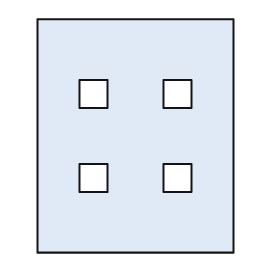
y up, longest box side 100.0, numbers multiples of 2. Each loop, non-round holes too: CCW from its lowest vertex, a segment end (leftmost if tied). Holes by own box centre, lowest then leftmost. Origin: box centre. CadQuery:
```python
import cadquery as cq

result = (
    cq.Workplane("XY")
    .moveTo(-42.0, -50.0)
    .lineTo(42.0, -50.0)
    .lineTo(42.0, 50.0)
    .lineTo(-42.0, 50.0)
    .close()
    .moveTo(-24.0, -24.0)
    .lineTo(-12.0, -24.0)
    .lineTo(-12.0, -12.0)
    .lineTo(-24.0, -12.0)
    .close()
    .moveTo(12.0, -24.0)
    .lineTo(24.0, -24.0)
    .lineTo(24.0, -12.0)
    .lineTo(12.0, -12.0)
    .close()
    .moveTo(-24.0, 12.0)
    .lineTo(-12.0, 12.0)
    .lineTo(-12.0, 24.0)
    .lineTo(-24.0, 24.0)
    .close()
    .moveTo(12.0, 12.0)
    .lineTo(24.0, 12.0)
    .lineTo(24.0, 24.0)
    .lineTo(12.0, 24.0)
    .close()
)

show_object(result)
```